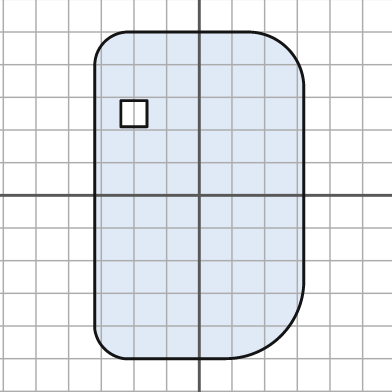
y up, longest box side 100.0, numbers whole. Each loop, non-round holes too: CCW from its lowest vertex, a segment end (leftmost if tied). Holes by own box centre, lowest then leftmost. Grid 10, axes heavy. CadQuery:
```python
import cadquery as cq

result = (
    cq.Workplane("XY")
    .moveTo(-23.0, -50.0)
    .lineTo(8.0, -50.0)
    .threePointArc((25.0, -43.0), (32.0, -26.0))
    .lineTo(32.0, 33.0)
    .threePointArc((27.0, 45.0), (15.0, 50.0))
    .lineTo(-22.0, 50.0)
    .threePointArc((-29.0, 47.0), (-32.0, 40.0))
    .lineTo(-32.0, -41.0)
    .threePointArc((-29.0, -47.0), (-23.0, -50.0))
    .close()
    .moveTo(-24.0, 21.0)
    .lineTo(-16.0, 21.0)
    .lineTo(-16.0, 29.0)
    .lineTo(-24.0, 29.0)
    .close()
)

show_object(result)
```